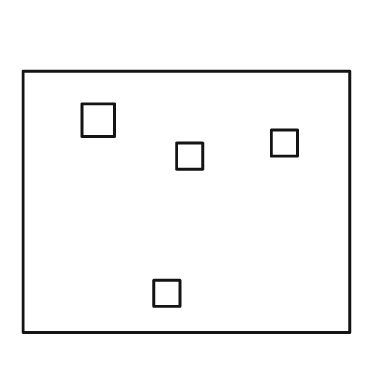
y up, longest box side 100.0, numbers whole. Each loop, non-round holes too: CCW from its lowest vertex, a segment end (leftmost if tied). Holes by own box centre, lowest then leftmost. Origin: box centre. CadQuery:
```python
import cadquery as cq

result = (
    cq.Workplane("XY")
    .moveTo(-50.0, -40.0)
    .lineTo(50.0, -40.0)
    .lineTo(50.0, 40.0)
    .lineTo(-50.0, 40.0)
    .close()
    .moveTo(-10.0, -32.0)
    .lineTo(-2.0, -32.0)
    .lineTo(-2.0, -24.0)
    .lineTo(-10.0, -24.0)
    .close()
    .moveTo(-3.0, 10.0)
    .lineTo(5.0, 10.0)
    .lineTo(5.0, 18.0)
    .lineTo(-3.0, 18.0)
    .close()
    .moveTo(26.0, 14.0)
    .lineTo(34.0, 14.0)
    .lineTo(34.0, 22.0)
    .lineTo(26.0, 22.0)
    .close()
    .moveTo(-32.0, 20.0)
    .lineTo(-22.0, 20.0)
    .lineTo(-22.0, 30.0)
    .lineTo(-32.0, 30.0)
    .close()
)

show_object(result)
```